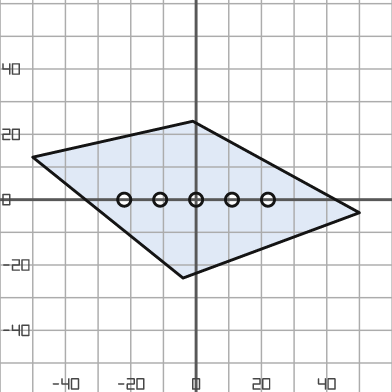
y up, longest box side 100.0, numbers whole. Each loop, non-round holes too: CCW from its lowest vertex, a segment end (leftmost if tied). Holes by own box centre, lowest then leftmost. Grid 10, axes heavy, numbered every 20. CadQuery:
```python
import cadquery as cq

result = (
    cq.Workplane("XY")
    .moveTo(-4.0, -24.0)
    .lineTo(50.0, -4.0)
    .lineTo(-1.0, 24.0)
    .lineTo(-50.0, 13.0)
    .close()
    .moveTo(-22.0, 0.0)
    .circle(2.0)
    .moveTo(-11.0, 0.0)
    .circle(2.0)
    .moveTo(0.0, 0.0)
    .circle(2.0)
    .moveTo(11.0, 0.0)
    .circle(2.0)
    .moveTo(22.0, 0.0)
    .circle(2.0)
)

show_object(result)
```